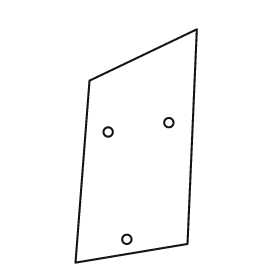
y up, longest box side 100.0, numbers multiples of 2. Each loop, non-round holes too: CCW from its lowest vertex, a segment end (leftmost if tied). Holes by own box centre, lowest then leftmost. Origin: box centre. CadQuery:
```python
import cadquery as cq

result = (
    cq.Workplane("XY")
    .moveTo(-26.0, -50.0)
    .lineTo(22.0, -42.0)
    .lineTo(26.0, 50.0)
    .lineTo(-20.0, 28.0)
    .close()
    .moveTo(-4.0, -40.0)
    .circle(2.0)
    .moveTo(-12.0, 6.0)
    .circle(2.0)
    .moveTo(14.0, 10.0)
    .circle(2.0)
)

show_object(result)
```